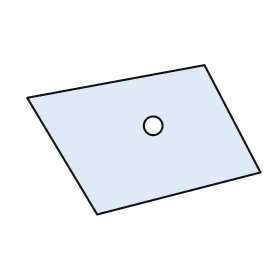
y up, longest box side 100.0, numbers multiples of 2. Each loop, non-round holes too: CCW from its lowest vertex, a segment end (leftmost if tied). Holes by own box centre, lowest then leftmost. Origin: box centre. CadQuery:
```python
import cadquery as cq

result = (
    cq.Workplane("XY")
    .moveTo(-20.0, -32.0)
    .lineTo(50.0, -14.0)
    .lineTo(26.0, 32.0)
    .lineTo(-50.0, 18.0)
    .close()
    .moveTo(4.0, 6.0)
    .circle(4.0)
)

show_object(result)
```